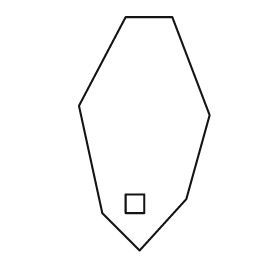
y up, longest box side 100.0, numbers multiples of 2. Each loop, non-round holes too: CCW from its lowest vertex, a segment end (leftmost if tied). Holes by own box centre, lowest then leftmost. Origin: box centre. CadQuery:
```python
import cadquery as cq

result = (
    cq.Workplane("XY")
    .moveTo(-2.0, -50.0)
    .lineTo(18.0, -28.0)
    .lineTo(28.0, 8.0)
    .lineTo(12.0, 50.0)
    .lineTo(-8.0, 50.0)
    .lineTo(-28.0, 12.0)
    .lineTo(-18.0, -34.0)
    .close()
    .moveTo(-8.0, -34.0)
    .lineTo(0.0, -34.0)
    .lineTo(0.0, -26.0)
    .lineTo(-8.0, -26.0)
    .close()
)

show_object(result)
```